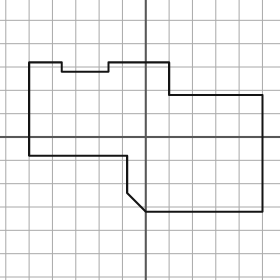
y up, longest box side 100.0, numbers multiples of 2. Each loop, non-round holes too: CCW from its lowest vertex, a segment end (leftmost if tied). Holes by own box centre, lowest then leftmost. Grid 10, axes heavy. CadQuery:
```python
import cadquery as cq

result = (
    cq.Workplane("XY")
    .moveTo(0.0, -32.0)
    .lineTo(50.0, -32.0)
    .lineTo(50.0, 18.0)
    .lineTo(10.0, 18.0)
    .lineTo(10.0, 32.0)
    .lineTo(-16.0, 32.0)
    .lineTo(-16.0, 28.0)
    .lineTo(-36.0, 28.0)
    .lineTo(-36.0, 32.0)
    .lineTo(-50.0, 32.0)
    .lineTo(-50.0, -8.0)
    .lineTo(-8.0, -8.0)
    .lineTo(-8.0, -24.0)
    .close()
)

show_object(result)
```